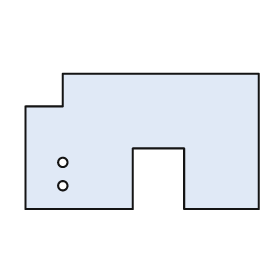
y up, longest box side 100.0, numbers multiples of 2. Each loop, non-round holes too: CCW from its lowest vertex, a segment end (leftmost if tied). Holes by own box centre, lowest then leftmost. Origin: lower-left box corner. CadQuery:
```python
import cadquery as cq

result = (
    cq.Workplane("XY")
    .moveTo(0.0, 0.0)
    .lineTo(46.0, 0.0)
    .lineTo(46.0, 26.0)
    .lineTo(68.0, 26.0)
    .lineTo(68.0, 0.0)
    .lineTo(100.0, 0.0)
    .lineTo(100.0, 58.0)
    .lineTo(16.0, 58.0)
    .lineTo(16.0, 44.0)
    .lineTo(0.0, 44.0)
    .close()
    .moveTo(16.0, 10.0)
    .circle(2.0)
    .moveTo(16.0, 20.0)
    .circle(2.0)
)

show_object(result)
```